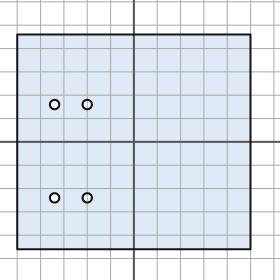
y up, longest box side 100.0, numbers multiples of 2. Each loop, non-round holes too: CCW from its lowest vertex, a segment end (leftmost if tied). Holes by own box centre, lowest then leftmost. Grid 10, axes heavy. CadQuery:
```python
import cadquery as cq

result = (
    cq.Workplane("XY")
    .moveTo(-50.0, -46.0)
    .lineTo(50.0, -46.0)
    .lineTo(50.0, 46.0)
    .lineTo(-50.0, 46.0)
    .close()
    .moveTo(-34.0, -24.0)
    .circle(2.0)
    .moveTo(-20.0, -24.0)
    .circle(2.0)
    .moveTo(-34.0, 16.0)
    .circle(2.0)
    .moveTo(-20.0, 16.0)
    .circle(2.0)
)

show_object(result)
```